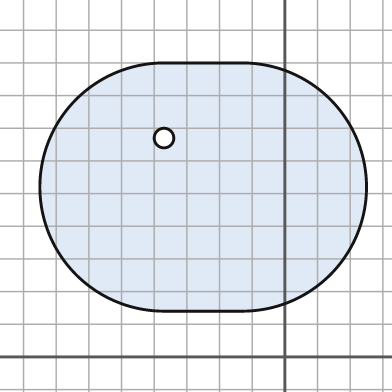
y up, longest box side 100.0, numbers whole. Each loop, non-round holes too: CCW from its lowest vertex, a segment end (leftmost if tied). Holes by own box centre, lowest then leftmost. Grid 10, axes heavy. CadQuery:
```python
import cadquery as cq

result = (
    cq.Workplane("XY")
    .moveTo(-37.0, 14.0)
    .lineTo(-13.0, 14.0)
    .threePointArc((25.0, 52.0), (-13.0, 90.0))
    .lineTo(-37.0, 90.0)
    .threePointArc((-75.0, 52.0), (-37.0, 14.0))
    .close()
    .moveTo(-37.0, 67.0)
    .circle(3.0)
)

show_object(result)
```